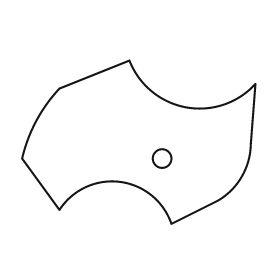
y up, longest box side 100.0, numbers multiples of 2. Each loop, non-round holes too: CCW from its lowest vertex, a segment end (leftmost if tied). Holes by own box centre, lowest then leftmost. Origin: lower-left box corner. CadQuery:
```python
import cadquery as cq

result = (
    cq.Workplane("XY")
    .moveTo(64.0, 0.0)
    .lineTo(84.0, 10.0)
    .threePointArc((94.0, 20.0), (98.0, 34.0))
    .lineTo(100.0, 60.0)
    .threePointArc((70.0, 50.0), (46.0, 70.0))
    .lineTo(16.0, 58.0)
    .threePointArc((6.0, 44.0), (0.0, 28.0))
    .lineTo(16.0, 6.0)
    .threePointArc((42.0, 18.0), (64.0, 0.0))
    .close()
    .moveTo(60.0, 28.0)
    .circle(4.0)
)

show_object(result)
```